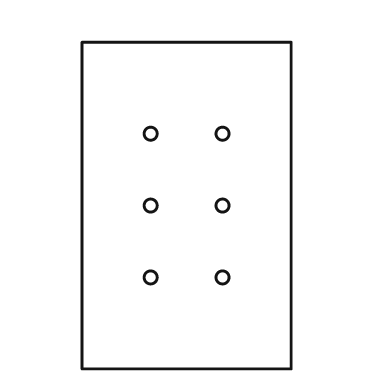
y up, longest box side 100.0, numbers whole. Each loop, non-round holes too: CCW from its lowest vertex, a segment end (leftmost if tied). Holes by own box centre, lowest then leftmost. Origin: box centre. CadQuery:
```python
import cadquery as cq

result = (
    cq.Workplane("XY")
    .moveTo(-32.0, -50.0)
    .lineTo(32.0, -50.0)
    .lineTo(32.0, 50.0)
    .lineTo(-32.0, 50.0)
    .close()
    .moveTo(-11.0, -22.0)
    .circle(2.0)
    .moveTo(11.0, -22.0)
    .circle(2.0)
    .moveTo(-11.0, 0.0)
    .circle(2.0)
    .moveTo(11.0, 0.0)
    .circle(2.0)
    .moveTo(-11.0, 22.0)
    .circle(2.0)
    .moveTo(11.0, 22.0)
    .circle(2.0)
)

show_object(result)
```